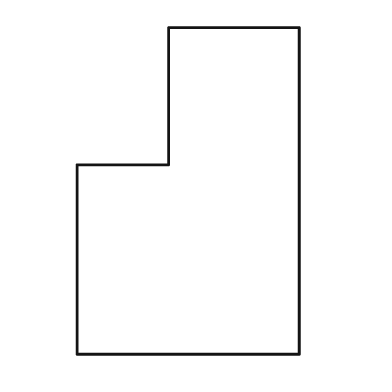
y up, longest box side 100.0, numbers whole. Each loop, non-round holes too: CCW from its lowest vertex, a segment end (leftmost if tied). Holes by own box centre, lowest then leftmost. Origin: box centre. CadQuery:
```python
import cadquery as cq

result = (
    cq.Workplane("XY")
    .moveTo(-34.0, -50.0)
    .lineTo(34.0, -50.0)
    .lineTo(34.0, 50.0)
    .lineTo(-6.0, 50.0)
    .lineTo(-6.0, 8.0)
    .lineTo(-34.0, 8.0)
    .close()
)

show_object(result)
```